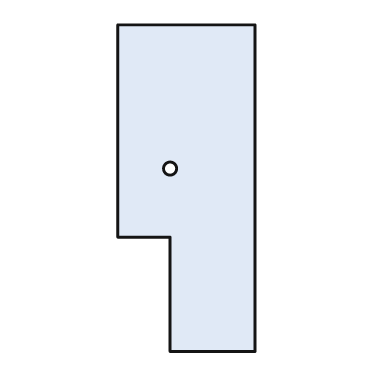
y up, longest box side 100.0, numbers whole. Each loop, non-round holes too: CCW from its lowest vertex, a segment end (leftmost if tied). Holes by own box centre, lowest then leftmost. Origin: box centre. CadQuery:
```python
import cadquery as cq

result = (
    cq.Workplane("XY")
    .moveTo(-5.0, -50.0)
    .lineTo(21.0, -50.0)
    .lineTo(21.0, 50.0)
    .lineTo(-21.0, 50.0)
    .lineTo(-21.0, -15.0)
    .lineTo(-5.0, -15.0)
    .close()
    .moveTo(-5.0, 6.0)
    .circle(2.0)
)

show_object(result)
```